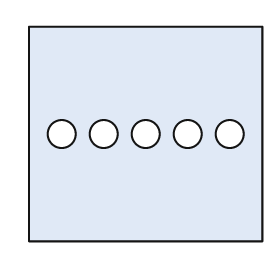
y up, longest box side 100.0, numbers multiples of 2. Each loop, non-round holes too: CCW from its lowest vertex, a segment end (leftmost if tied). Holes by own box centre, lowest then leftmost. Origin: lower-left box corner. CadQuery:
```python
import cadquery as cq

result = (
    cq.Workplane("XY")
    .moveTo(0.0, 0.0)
    .lineTo(100.0, 0.0)
    .lineTo(100.0, 92.0)
    .lineTo(0.0, 92.0)
    .close()
    .moveTo(14.0, 46.0)
    .circle(6.0)
    .moveTo(32.0, 46.0)
    .circle(6.0)
    .moveTo(50.0, 46.0)
    .circle(6.0)
    .moveTo(68.0, 46.0)
    .circle(6.0)
    .moveTo(86.0, 46.0)
    .circle(6.0)
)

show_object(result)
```